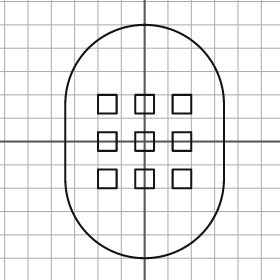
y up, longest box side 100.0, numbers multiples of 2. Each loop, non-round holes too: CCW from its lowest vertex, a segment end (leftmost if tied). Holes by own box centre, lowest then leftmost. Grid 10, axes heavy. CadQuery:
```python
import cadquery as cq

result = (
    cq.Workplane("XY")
    .moveTo(-34.0, -16.0)
    .threePointArc((0.0, -50.0), (34.0, -16.0))
    .lineTo(34.0, 16.0)
    .threePointArc((0.0, 50.0), (-34.0, 16.0))
    .close()
    .moveTo(-20.0, -20.0)
    .lineTo(-12.0, -20.0)
    .lineTo(-12.0, -12.0)
    .lineTo(-20.0, -12.0)
    .close()
    .moveTo(-4.0, -20.0)
    .lineTo(4.0, -20.0)
    .lineTo(4.0, -12.0)
    .lineTo(-4.0, -12.0)
    .close()
    .moveTo(12.0, -20.0)
    .lineTo(20.0, -20.0)
    .lineTo(20.0, -12.0)
    .lineTo(12.0, -12.0)
    .close()
    .moveTo(-20.0, -4.0)
    .lineTo(-12.0, -4.0)
    .lineTo(-12.0, 4.0)
    .lineTo(-20.0, 4.0)
    .close()
    .moveTo(-4.0, -4.0)
    .lineTo(4.0, -4.0)
    .lineTo(4.0, 4.0)
    .lineTo(-4.0, 4.0)
    .close()
    .moveTo(12.0, -4.0)
    .lineTo(20.0, -4.0)
    .lineTo(20.0, 4.0)
    .lineTo(12.0, 4.0)
    .close()
    .moveTo(-20.0, 12.0)
    .lineTo(-12.0, 12.0)
    .lineTo(-12.0, 20.0)
    .lineTo(-20.0, 20.0)
    .close()
    .moveTo(-4.0, 12.0)
    .lineTo(4.0, 12.0)
    .lineTo(4.0, 20.0)
    .lineTo(-4.0, 20.0)
    .close()
    .moveTo(12.0, 12.0)
    .lineTo(20.0, 12.0)
    .lineTo(20.0, 20.0)
    .lineTo(12.0, 20.0)
    .close()
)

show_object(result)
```